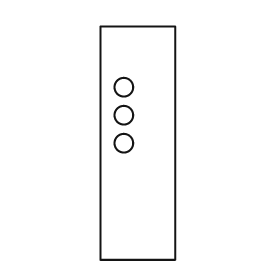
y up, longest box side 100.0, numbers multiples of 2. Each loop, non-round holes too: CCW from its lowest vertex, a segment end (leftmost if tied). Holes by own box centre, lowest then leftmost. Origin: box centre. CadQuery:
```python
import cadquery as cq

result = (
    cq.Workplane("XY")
    .moveTo(-16.0, -50.0)
    .lineTo(16.0, -50.0)
    .lineTo(16.0, 50.0)
    .lineTo(-16.0, 50.0)
    .close()
    .moveTo(-6.0, 0.0)
    .circle(4.0)
    .moveTo(-6.0, 12.0)
    .circle(4.0)
    .moveTo(-6.0, 24.0)
    .circle(4.0)
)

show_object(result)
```